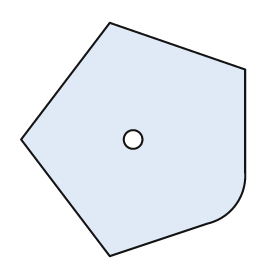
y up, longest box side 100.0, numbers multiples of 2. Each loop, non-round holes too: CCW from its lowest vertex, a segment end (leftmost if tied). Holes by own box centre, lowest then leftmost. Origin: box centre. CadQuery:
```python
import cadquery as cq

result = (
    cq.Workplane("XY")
    .moveTo(-10.0, -50.0)
    .lineTo(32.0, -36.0)
    .threePointArc((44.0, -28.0), (48.0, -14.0))
    .lineTo(48.0, 30.0)
    .lineTo(-10.0, 50.0)
    .lineTo(-48.0, 0.0)
    .close()
    .moveTo(0.0, 0.0)
    .circle(4.0)
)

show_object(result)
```